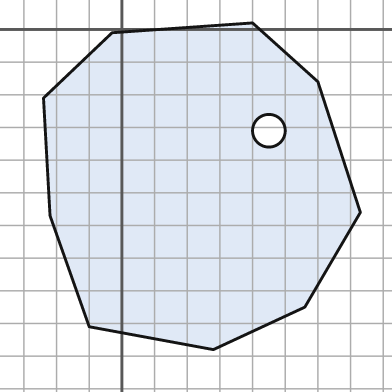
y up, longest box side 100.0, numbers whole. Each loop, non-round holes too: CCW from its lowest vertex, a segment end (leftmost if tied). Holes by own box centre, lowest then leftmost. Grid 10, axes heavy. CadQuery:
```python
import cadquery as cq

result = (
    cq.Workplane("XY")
    .moveTo(28.0, -98.0)
    .lineTo(56.0, -85.0)
    .lineTo(73.0, -56.0)
    .lineTo(60.0, -16.0)
    .lineTo(40.0, 2.0)
    .lineTo(-3.0, -1.0)
    .lineTo(-24.0, -21.0)
    .lineTo(-22.0, -57.0)
    .lineTo(-10.0, -91.0)
    .close()
    .moveTo(45.0, -31.0)
    .circle(5.0)
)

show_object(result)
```